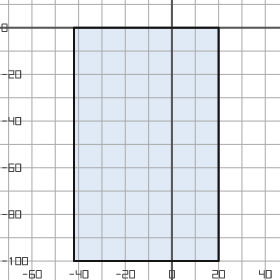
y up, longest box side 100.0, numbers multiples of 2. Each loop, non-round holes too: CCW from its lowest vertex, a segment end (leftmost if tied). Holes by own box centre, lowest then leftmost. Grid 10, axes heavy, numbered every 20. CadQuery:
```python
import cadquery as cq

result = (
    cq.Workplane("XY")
    .moveTo(-42.0, -100.0)
    .lineTo(20.0, -100.0)
    .lineTo(20.0, 0.0)
    .lineTo(-42.0, 0.0)
    .close()
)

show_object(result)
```